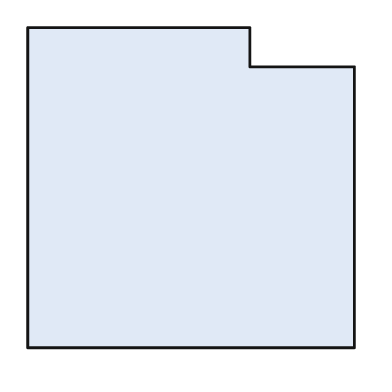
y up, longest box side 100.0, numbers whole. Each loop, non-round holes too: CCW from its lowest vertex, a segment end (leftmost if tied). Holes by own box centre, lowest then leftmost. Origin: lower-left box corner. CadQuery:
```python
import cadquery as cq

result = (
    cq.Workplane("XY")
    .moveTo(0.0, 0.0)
    .lineTo(100.0, 0.0)
    .lineTo(100.0, 86.0)
    .lineTo(68.0, 86.0)
    .lineTo(68.0, 98.0)
    .lineTo(0.0, 98.0)
    .close()
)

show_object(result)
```